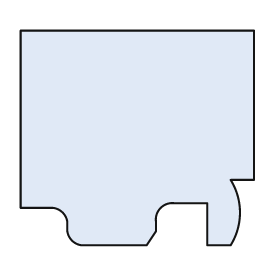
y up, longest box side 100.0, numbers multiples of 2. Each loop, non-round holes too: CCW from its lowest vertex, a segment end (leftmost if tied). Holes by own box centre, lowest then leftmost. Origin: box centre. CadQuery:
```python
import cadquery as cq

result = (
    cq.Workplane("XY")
    .moveTo(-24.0, -46.0)
    .lineTo(4.0, -46.0)
    .lineTo(8.0, -40.0)
    .lineTo(8.0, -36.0)
    .threePointArc((10.0, -30.0), (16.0, -28.0))
    .lineTo(30.0, -28.0)
    .lineTo(30.0, -46.0)
    .lineTo(40.0, -46.0)
    .threePointArc((44.0, -32.0), (40.0, -18.0))
    .lineTo(50.0, -18.0)
    .lineTo(50.0, 46.0)
    .lineTo(-50.0, 46.0)
    .lineTo(-50.0, -30.0)
    .lineTo(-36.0, -30.0)
    .threePointArc((-32.0, -32.0), (-30.0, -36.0))
    .lineTo(-30.0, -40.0)
    .threePointArc((-28.0, -44.0), (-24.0, -46.0))
    .close()
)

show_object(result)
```